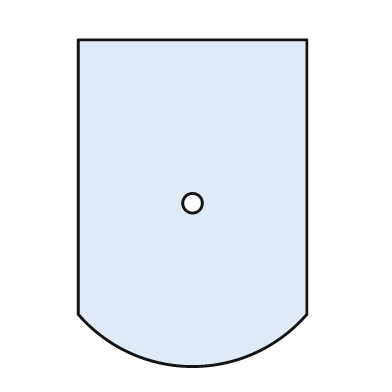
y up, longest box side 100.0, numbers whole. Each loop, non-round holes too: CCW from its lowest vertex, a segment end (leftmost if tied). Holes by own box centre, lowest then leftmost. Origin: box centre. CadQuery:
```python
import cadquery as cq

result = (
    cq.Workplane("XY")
    .moveTo(-35.0, -34.0)
    .threePointArc((0.0, -50.0), (35.0, -34.0))
    .lineTo(35.0, 50.0)
    .lineTo(-35.0, 50.0)
    .close()
    .moveTo(0.0, 0.0)
    .circle(3.0)
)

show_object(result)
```